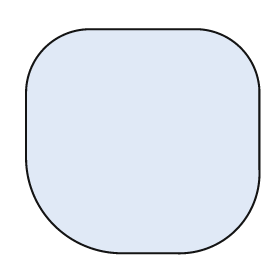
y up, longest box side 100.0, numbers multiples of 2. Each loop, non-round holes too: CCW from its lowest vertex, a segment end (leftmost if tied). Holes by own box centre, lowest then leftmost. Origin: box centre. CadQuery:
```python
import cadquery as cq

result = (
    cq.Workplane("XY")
    .moveTo(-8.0, -48.0)
    .lineTo(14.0, -48.0)
    .threePointArc((40.0, -38.0), (50.0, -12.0))
    .lineTo(50.0, 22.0)
    .threePointArc((42.0, 40.0), (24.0, 48.0))
    .lineTo(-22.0, 48.0)
    .threePointArc((-42.0, 40.0), (-50.0, 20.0))
    .lineTo(-50.0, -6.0)
    .threePointArc((-38.0, -36.0), (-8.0, -48.0))
    .close()
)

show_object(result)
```